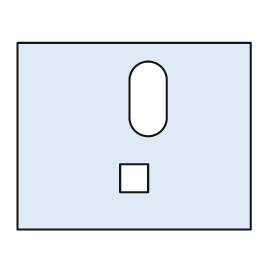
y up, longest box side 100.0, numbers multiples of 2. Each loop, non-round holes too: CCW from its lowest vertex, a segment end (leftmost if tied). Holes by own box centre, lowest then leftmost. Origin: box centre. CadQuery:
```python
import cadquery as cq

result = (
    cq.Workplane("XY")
    .moveTo(-50.0, -40.0)
    .lineTo(50.0, -40.0)
    .lineTo(50.0, 40.0)
    .lineTo(-50.0, 40.0)
    .close()
    .moveTo(-6.0, -24.0)
    .lineTo(6.0, -24.0)
    .lineTo(6.0, -12.0)
    .lineTo(-6.0, -12.0)
    .close()
    .moveTo(-2.0, 8.0)
    .threePointArc((6.0, 0.0), (14.0, 8.0))
    .lineTo(14.0, 24.0)
    .threePointArc((6.0, 32.0), (-2.0, 24.0))
    .close()
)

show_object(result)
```